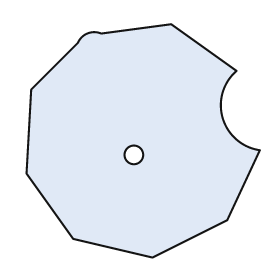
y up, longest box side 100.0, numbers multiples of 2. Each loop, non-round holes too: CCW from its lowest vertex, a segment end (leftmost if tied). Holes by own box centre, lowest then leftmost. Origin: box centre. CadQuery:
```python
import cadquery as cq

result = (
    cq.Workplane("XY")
    .moveTo(4.0, -50.0)
    .lineTo(36.0, -34.0)
    .lineTo(50.0, -4.0)
    .threePointArc((34.0, 10.0), (40.0, 30.0))
    .lineTo(12.0, 50.0)
    .lineTo(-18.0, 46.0)
    .threePointArc((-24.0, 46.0), (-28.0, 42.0))
    .lineTo(-48.0, 22.0)
    .lineTo(-50.0, -14.0)
    .lineTo(-30.0, -42.0)
    .close()
    .moveTo(-4.0, -6.0)
    .circle(4.0)
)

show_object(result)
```